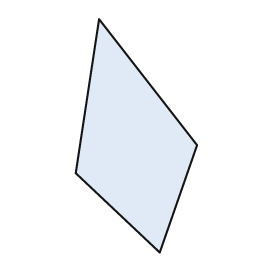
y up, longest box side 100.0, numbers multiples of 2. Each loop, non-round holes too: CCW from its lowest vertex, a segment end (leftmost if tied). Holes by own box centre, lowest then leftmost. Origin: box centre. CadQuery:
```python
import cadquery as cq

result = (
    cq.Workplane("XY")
    .moveTo(10.0, -50.0)
    .lineTo(26.0, -4.0)
    .lineTo(-16.0, 50.0)
    .lineTo(-26.0, -16.0)
    .close()
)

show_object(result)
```